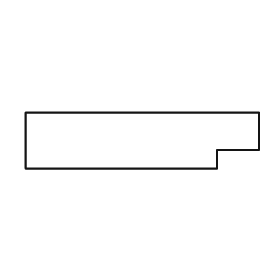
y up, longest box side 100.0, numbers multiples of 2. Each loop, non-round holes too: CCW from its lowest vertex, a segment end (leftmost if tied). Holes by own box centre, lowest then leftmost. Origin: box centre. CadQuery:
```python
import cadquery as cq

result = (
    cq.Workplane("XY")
    .moveTo(-50.0, -12.0)
    .lineTo(32.0, -12.0)
    .lineTo(32.0, -4.0)
    .lineTo(50.0, -4.0)
    .lineTo(50.0, 12.0)
    .lineTo(-50.0, 12.0)
    .close()
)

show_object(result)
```